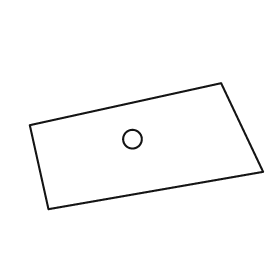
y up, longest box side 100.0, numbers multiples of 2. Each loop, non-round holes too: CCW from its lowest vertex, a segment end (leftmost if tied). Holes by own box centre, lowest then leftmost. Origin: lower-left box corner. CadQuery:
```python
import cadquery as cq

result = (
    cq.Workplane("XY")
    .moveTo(8.0, 0.0)
    .lineTo(100.0, 16.0)
    .lineTo(82.0, 54.0)
    .lineTo(0.0, 36.0)
    .close()
    .moveTo(44.0, 30.0)
    .circle(4.0)
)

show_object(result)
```